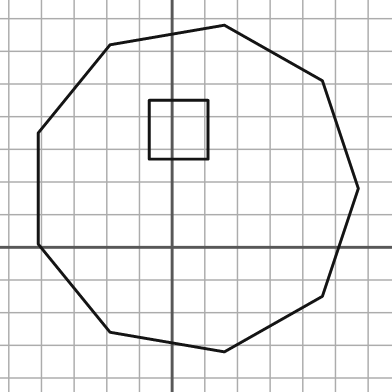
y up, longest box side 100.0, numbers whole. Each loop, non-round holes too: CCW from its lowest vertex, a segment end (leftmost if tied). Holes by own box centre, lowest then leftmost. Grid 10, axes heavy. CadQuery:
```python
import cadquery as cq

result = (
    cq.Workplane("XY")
    .moveTo(16.0, -32.0)
    .lineTo(46.0, -15.0)
    .lineTo(57.0, 18.0)
    .lineTo(46.0, 51.0)
    .lineTo(16.0, 68.0)
    .lineTo(-19.0, 62.0)
    .lineTo(-41.0, 35.0)
    .lineTo(-41.0, 1.0)
    .lineTo(-19.0, -26.0)
    .close()
    .moveTo(-7.0, 27.0)
    .lineTo(11.0, 27.0)
    .lineTo(11.0, 45.0)
    .lineTo(-7.0, 45.0)
    .close()
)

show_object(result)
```